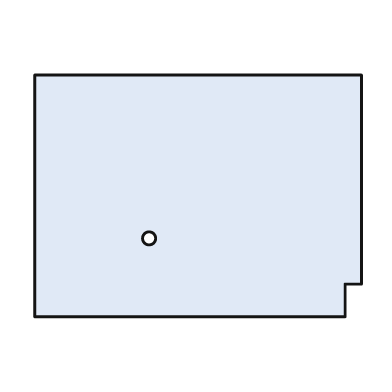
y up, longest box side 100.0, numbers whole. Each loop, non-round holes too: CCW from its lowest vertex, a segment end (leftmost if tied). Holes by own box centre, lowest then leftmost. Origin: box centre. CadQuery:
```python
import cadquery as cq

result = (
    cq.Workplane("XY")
    .moveTo(-50.0, -37.0)
    .lineTo(45.0, -37.0)
    .lineTo(45.0, -27.0)
    .lineTo(50.0, -27.0)
    .lineTo(50.0, 37.0)
    .lineTo(-50.0, 37.0)
    .close()
    .moveTo(-15.0, -13.0)
    .circle(2.0)
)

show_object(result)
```